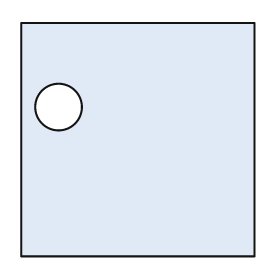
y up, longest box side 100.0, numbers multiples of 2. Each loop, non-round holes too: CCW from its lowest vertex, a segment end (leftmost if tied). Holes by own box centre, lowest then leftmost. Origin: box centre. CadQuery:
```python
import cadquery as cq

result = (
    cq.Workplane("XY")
    .moveTo(-50.0, -50.0)
    .lineTo(50.0, -50.0)
    .lineTo(50.0, 50.0)
    .lineTo(-50.0, 50.0)
    .close()
    .moveTo(-34.0, 14.0)
    .circle(10.0)
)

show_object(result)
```